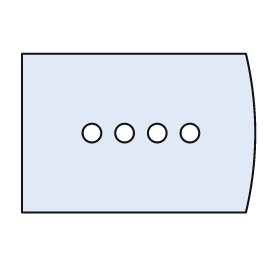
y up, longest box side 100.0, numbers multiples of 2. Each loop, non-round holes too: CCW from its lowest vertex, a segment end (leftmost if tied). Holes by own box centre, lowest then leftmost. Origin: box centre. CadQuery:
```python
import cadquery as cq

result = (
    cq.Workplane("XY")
    .moveTo(-50.0, -34.0)
    .lineTo(46.0, -34.0)
    .threePointArc((50.0, 0.0), (46.0, 34.0))
    .lineTo(-50.0, 34.0)
    .close()
    .moveTo(-20.0, 0.0)
    .circle(4.0)
    .moveTo(-6.0, 0.0)
    .circle(4.0)
    .moveTo(8.0, 0.0)
    .circle(4.0)
    .moveTo(22.0, 0.0)
    .circle(4.0)
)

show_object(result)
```